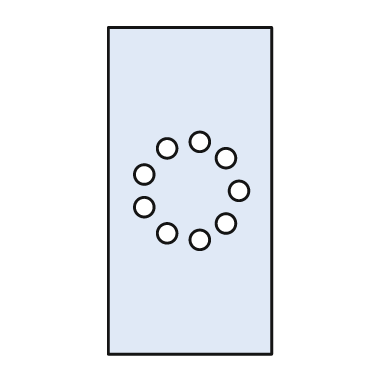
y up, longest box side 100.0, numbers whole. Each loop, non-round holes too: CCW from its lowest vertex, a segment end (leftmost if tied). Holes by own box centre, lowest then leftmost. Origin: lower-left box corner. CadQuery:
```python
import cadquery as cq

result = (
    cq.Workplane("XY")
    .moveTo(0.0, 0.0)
    .lineTo(50.0, 0.0)
    .lineTo(50.0, 100.0)
    .lineTo(0.0, 100.0)
    .close()
    .moveTo(28.0, 35.0)
    .circle(3.0)
    .moveTo(18.0, 37.0)
    .circle(3.0)
    .moveTo(36.0, 40.0)
    .circle(3.0)
    .moveTo(11.0, 45.0)
    .circle(3.0)
    .moveTo(40.0, 50.0)
    .circle(3.0)
    .moveTo(11.0, 55.0)
    .circle(3.0)
    .moveTo(36.0, 60.0)
    .circle(3.0)
    .moveTo(18.0, 63.0)
    .circle(3.0)
    .moveTo(28.0, 65.0)
    .circle(3.0)
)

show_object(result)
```